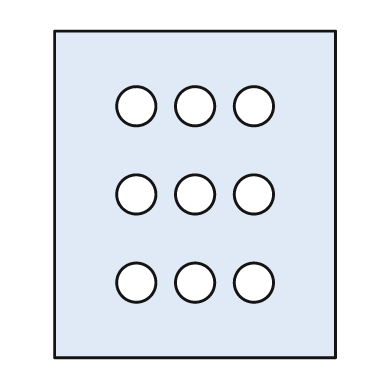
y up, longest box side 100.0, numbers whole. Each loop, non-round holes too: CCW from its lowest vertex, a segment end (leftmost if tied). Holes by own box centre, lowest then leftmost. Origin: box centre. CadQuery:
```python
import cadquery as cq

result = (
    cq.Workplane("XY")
    .moveTo(-43.0, -50.0)
    .lineTo(43.0, -50.0)
    .lineTo(43.0, 50.0)
    .lineTo(-43.0, 50.0)
    .close()
    .moveTo(-18.0, -27.0)
    .circle(6.0)
    .moveTo(0.0, -27.0)
    .circle(6.0)
    .moveTo(18.0, -27.0)
    .circle(6.0)
    .moveTo(-18.0, 0.0)
    .circle(6.0)
    .moveTo(0.0, 0.0)
    .circle(6.0)
    .moveTo(18.0, 0.0)
    .circle(6.0)
    .moveTo(-18.0, 27.0)
    .circle(6.0)
    .moveTo(0.0, 27.0)
    .circle(6.0)
    .moveTo(18.0, 27.0)
    .circle(6.0)
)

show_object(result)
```